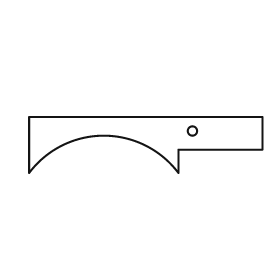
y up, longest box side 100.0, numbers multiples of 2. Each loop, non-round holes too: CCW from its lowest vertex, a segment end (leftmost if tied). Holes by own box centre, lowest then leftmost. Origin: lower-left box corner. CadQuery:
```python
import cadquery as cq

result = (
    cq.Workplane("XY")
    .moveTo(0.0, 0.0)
    .threePointArc((32.0, 16.0), (64.0, 0.0))
    .lineTo(64.0, 10.0)
    .lineTo(100.0, 10.0)
    .lineTo(100.0, 24.0)
    .lineTo(0.0, 24.0)
    .close()
    .moveTo(70.0, 18.0)
    .circle(2.0)
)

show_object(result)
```